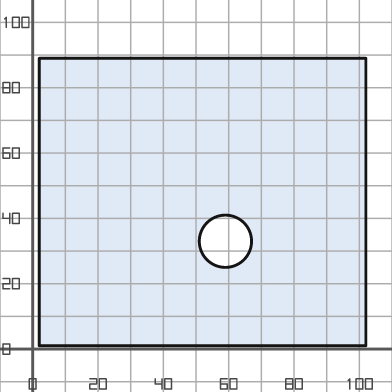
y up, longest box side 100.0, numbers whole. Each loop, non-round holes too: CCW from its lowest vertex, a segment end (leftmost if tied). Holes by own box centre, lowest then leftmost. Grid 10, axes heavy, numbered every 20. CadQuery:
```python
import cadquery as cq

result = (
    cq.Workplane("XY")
    .moveTo(2.0, 1.0)
    .lineTo(102.0, 1.0)
    .lineTo(102.0, 89.0)
    .lineTo(2.0, 89.0)
    .close()
    .moveTo(59.0, 33.0)
    .circle(8.0)
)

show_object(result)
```